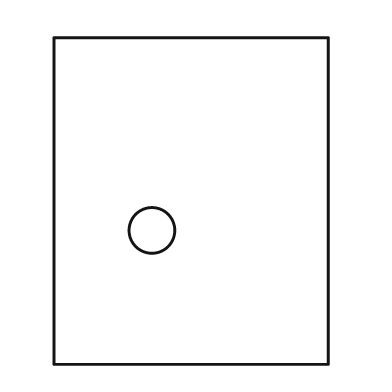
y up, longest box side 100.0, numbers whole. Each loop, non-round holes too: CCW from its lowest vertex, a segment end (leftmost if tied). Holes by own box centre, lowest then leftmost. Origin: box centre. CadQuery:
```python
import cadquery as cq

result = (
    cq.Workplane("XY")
    .moveTo(-42.0, -50.0)
    .lineTo(42.0, -50.0)
    .lineTo(42.0, 50.0)
    .lineTo(-42.0, 50.0)
    .close()
    .moveTo(-12.0, -9.0)
    .circle(7.0)
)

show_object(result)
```